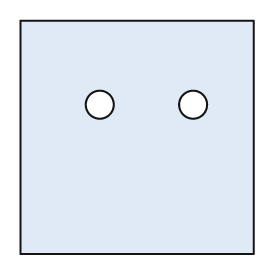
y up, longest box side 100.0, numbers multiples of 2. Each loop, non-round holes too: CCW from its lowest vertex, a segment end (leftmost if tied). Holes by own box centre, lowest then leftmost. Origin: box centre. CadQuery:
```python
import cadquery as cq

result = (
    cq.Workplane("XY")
    .moveTo(-50.0, -50.0)
    .lineTo(50.0, -50.0)
    .lineTo(50.0, 50.0)
    .lineTo(-50.0, 50.0)
    .close()
    .moveTo(-16.0, 14.0)
    .circle(6.0)
    .moveTo(24.0, 14.0)
    .circle(6.0)
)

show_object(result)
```